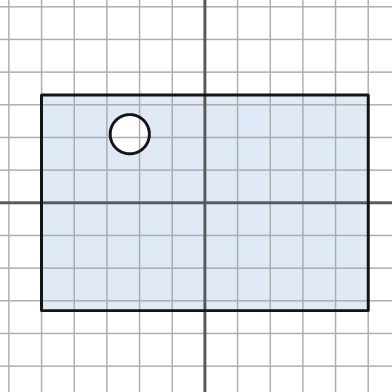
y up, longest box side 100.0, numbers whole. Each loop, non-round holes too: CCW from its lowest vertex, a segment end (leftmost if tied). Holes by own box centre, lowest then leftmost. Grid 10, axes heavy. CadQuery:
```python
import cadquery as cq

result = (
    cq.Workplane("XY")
    .moveTo(-50.0, -33.0)
    .lineTo(50.0, -33.0)
    .lineTo(50.0, 33.0)
    .lineTo(-50.0, 33.0)
    .close()
    .moveTo(-23.0, 21.0)
    .circle(6.0)
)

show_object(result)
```